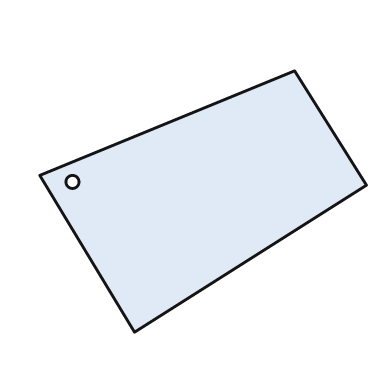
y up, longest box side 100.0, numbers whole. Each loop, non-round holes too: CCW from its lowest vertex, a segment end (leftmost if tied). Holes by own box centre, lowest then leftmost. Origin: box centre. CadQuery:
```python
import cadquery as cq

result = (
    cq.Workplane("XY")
    .moveTo(-21.0, -40.0)
    .lineTo(50.0, 5.0)
    .lineTo(28.0, 40.0)
    .lineTo(-50.0, 8.0)
    .close()
    .moveTo(-40.0, 6.0)
    .circle(2.0)
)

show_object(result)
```